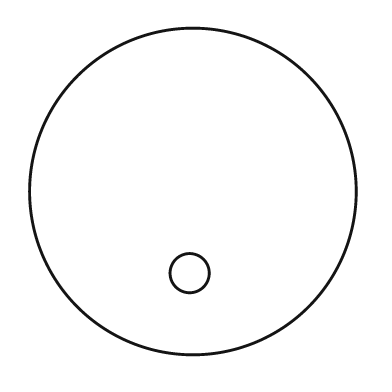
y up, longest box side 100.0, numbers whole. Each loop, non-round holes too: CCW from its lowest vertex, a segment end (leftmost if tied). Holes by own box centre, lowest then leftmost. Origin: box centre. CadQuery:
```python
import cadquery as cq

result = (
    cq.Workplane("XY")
    .moveTo(0.0, 0.0)
    .circle(50.0)
    .moveTo(-1.0, -25.0)
    .circle(6.0)
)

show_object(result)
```